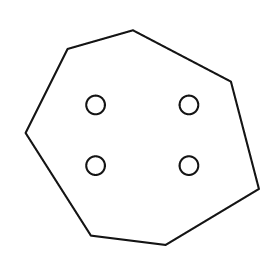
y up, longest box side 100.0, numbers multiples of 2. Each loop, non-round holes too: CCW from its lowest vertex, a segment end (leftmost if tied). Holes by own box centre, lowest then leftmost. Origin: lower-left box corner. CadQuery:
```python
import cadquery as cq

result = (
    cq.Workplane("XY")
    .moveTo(60.0, 0.0)
    .lineTo(100.0, 24.0)
    .lineTo(88.0, 70.0)
    .lineTo(46.0, 92.0)
    .lineTo(18.0, 84.0)
    .lineTo(0.0, 48.0)
    .lineTo(28.0, 4.0)
    .close()
    .moveTo(30.0, 34.0)
    .circle(4.0)
    .moveTo(70.0, 34.0)
    .circle(4.0)
    .moveTo(30.0, 60.0)
    .circle(4.0)
    .moveTo(70.0, 60.0)
    .circle(4.0)
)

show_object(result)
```